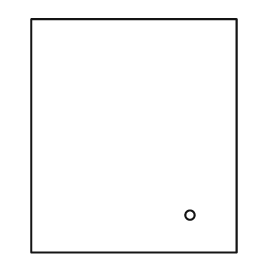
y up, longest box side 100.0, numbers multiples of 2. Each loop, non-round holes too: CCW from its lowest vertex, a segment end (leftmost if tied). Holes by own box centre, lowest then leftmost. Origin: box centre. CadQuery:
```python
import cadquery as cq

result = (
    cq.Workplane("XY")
    .moveTo(-44.0, -50.0)
    .lineTo(44.0, -50.0)
    .lineTo(44.0, 50.0)
    .lineTo(-44.0, 50.0)
    .close()
    .moveTo(24.0, -34.0)
    .circle(2.0)
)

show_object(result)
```